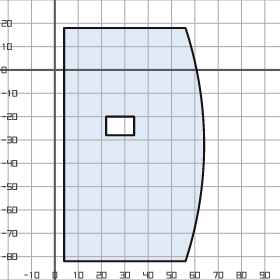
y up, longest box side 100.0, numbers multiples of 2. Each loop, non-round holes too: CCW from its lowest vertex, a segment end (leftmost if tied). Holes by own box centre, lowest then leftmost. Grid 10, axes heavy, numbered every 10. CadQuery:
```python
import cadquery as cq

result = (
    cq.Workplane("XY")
    .moveTo(4.0, -82.0)
    .lineTo(56.0, -82.0)
    .threePointArc((64.0, -32.0), (56.0, 18.0))
    .lineTo(4.0, 18.0)
    .close()
    .moveTo(22.0, -28.0)
    .lineTo(34.0, -28.0)
    .lineTo(34.0, -20.0)
    .lineTo(22.0, -20.0)
    .close()
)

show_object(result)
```